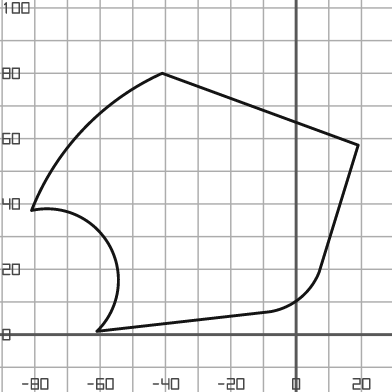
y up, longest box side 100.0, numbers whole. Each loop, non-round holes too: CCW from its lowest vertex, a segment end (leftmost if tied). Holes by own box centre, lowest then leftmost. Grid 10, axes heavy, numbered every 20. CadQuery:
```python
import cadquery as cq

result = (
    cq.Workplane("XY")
    .moveTo(-61.0, 1.0)
    .lineTo(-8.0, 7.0)
    .threePointArc((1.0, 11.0), (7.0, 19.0))
    .lineTo(19.0, 58.0)
    .lineTo(-41.0, 80.0)
    .threePointArc((-65.0, 63.0), (-81.0, 38.0))
    .threePointArc((-57.0, 27.0), (-61.0, 1.0))
    .close()
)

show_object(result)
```